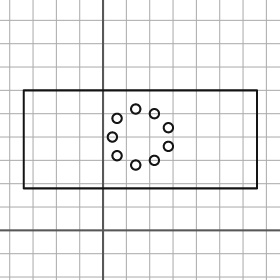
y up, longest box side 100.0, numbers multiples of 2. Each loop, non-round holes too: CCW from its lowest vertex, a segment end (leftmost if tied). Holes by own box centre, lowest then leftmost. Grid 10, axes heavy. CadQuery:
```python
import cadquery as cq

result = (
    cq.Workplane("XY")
    .moveTo(-34.0, 18.0)
    .lineTo(66.0, 18.0)
    .lineTo(66.0, 60.0)
    .lineTo(-34.0, 60.0)
    .close()
    .moveTo(14.0, 28.0)
    .circle(2.0)
    .moveTo(22.0, 30.0)
    .circle(2.0)
    .moveTo(6.0, 32.0)
    .circle(2.0)
    .moveTo(28.0, 36.0)
    .circle(2.0)
    .moveTo(4.0, 40.0)
    .circle(2.0)
    .moveTo(28.0, 44.0)
    .circle(2.0)
    .moveTo(6.0, 48.0)
    .circle(2.0)
    .moveTo(22.0, 50.0)
    .circle(2.0)
    .moveTo(14.0, 52.0)
    .circle(2.0)
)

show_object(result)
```